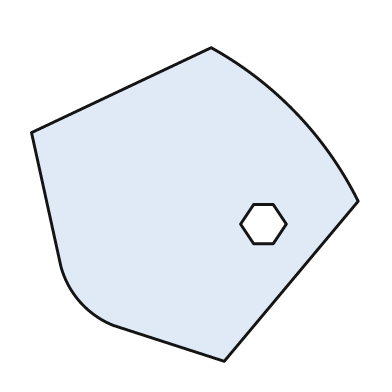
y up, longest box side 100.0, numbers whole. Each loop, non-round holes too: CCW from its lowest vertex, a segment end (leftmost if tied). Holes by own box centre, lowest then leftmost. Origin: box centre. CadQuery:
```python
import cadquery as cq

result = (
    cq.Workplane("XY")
    .moveTo(9.0, -48.0)
    .lineTo(50.0, 1.0)
    .threePointArc((31.0, 28.0), (5.0, 48.0))
    .lineTo(-50.0, 22.0)
    .lineTo(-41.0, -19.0)
    .threePointArc((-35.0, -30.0), (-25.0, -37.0))
    .close()
    .moveTo(18.0, -12.0)
    .lineTo(24.0, -12.0)
    .lineTo(28.0, -6.0)
    .lineTo(24.0, 0.0)
    .lineTo(18.0, 0.0)
    .lineTo(14.0, -6.0)
    .close()
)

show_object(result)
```